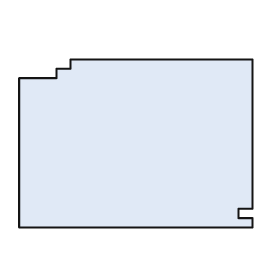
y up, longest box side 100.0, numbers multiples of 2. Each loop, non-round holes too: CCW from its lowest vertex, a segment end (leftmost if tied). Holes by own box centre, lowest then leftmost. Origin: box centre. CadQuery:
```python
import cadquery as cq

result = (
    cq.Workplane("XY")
    .moveTo(-50.0, -36.0)
    .lineTo(50.0, -36.0)
    .lineTo(50.0, -32.0)
    .lineTo(44.0, -32.0)
    .lineTo(44.0, -28.0)
    .lineTo(50.0, -28.0)
    .lineTo(50.0, 36.0)
    .lineTo(-28.0, 36.0)
    .lineTo(-28.0, 32.0)
    .lineTo(-34.0, 32.0)
    .lineTo(-34.0, 28.0)
    .lineTo(-50.0, 28.0)
    .close()
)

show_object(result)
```